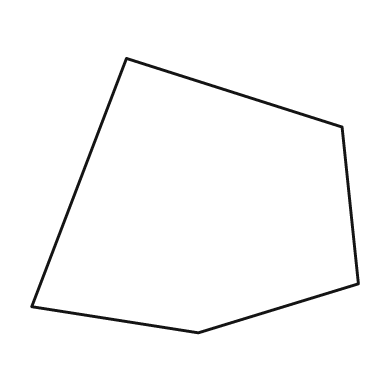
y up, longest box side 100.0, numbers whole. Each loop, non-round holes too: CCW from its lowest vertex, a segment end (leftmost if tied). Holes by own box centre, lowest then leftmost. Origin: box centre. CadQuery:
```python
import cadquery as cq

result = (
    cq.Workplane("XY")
    .moveTo(1.0, -42.0)
    .lineTo(50.0, -27.0)
    .lineTo(45.0, 21.0)
    .lineTo(-21.0, 42.0)
    .lineTo(-50.0, -34.0)
    .close()
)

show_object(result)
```